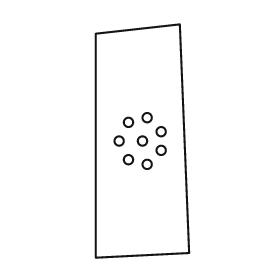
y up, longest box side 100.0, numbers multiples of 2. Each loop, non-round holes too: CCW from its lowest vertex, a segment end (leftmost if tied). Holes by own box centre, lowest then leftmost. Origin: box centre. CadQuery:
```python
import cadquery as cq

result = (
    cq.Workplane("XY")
    .moveTo(-20.0, -50.0)
    .lineTo(20.0, -48.0)
    .lineTo(16.0, 50.0)
    .lineTo(-20.0, 46.0)
    .close()
    .moveTo(2.0, -10.0)
    .circle(2.0)
    .moveTo(-6.0, -8.0)
    .circle(2.0)
    .moveTo(8.0, -4.0)
    .circle(2.0)
    .moveTo(-10.0, 0.0)
    .circle(2.0)
    .moveTo(0.0, 0.0)
    .circle(2.0)
    .moveTo(8.0, 4.0)
    .circle(2.0)
    .moveTo(-6.0, 8.0)
    .circle(2.0)
    .moveTo(2.0, 10.0)
    .circle(2.0)
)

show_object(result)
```